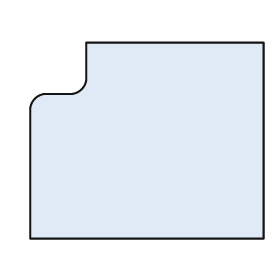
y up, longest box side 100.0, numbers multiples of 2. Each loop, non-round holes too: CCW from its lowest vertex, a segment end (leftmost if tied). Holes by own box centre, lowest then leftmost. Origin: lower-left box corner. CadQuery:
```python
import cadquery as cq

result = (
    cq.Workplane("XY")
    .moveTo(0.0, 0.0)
    .lineTo(100.0, 0.0)
    .lineTo(100.0, 84.0)
    .lineTo(24.0, 84.0)
    .lineTo(24.0, 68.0)
    .threePointArc((22.0, 64.0), (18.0, 62.0))
    .lineTo(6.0, 62.0)
    .threePointArc((2.0, 60.0), (0.0, 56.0))
    .close()
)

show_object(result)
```